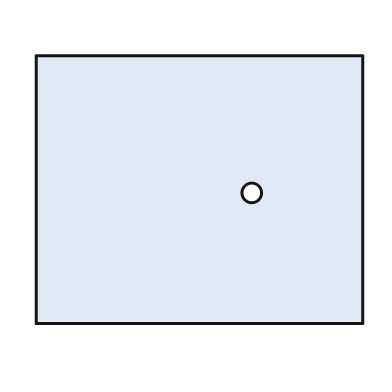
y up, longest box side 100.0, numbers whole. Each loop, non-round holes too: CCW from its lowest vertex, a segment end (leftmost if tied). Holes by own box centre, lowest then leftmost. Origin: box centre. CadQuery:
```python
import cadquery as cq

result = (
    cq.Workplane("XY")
    .moveTo(-50.0, -41.0)
    .lineTo(50.0, -41.0)
    .lineTo(50.0, 41.0)
    .lineTo(-50.0, 41.0)
    .close()
    .moveTo(16.0, -1.0)
    .circle(3.0)
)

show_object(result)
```